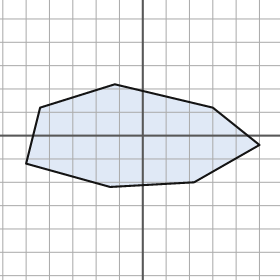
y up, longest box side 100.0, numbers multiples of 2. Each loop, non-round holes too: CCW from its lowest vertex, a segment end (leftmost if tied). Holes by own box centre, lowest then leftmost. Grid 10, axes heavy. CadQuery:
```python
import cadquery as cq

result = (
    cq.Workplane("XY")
    .moveTo(-14.0, -22.0)
    .lineTo(22.0, -20.0)
    .lineTo(50.0, -4.0)
    .lineTo(30.0, 12.0)
    .lineTo(-12.0, 22.0)
    .lineTo(-44.0, 12.0)
    .lineTo(-50.0, -12.0)
    .close()
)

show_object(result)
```